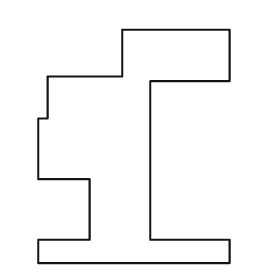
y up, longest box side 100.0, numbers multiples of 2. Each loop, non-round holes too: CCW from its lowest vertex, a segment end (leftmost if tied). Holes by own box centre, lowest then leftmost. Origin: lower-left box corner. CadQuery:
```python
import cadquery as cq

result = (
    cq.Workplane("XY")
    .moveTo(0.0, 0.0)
    .lineTo(82.0, 0.0)
    .lineTo(82.0, 10.0)
    .lineTo(48.0, 10.0)
    .lineTo(48.0, 78.0)
    .lineTo(82.0, 78.0)
    .lineTo(82.0, 100.0)
    .lineTo(36.0, 100.0)
    .lineTo(36.0, 80.0)
    .lineTo(4.0, 80.0)
    .lineTo(4.0, 62.0)
    .lineTo(0.0, 62.0)
    .lineTo(0.0, 36.0)
    .lineTo(22.0, 36.0)
    .lineTo(22.0, 10.0)
    .lineTo(0.0, 10.0)
    .close()
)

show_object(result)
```